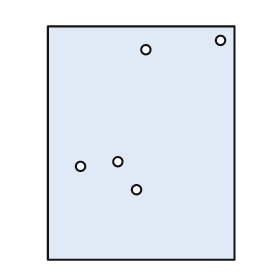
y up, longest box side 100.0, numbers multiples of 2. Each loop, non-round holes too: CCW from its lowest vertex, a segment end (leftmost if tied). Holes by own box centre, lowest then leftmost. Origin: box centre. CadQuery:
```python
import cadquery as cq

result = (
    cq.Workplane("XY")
    .moveTo(-40.0, -50.0)
    .lineTo(40.0, -50.0)
    .lineTo(40.0, 50.0)
    .lineTo(-40.0, 50.0)
    .close()
    .moveTo(-2.0, -20.0)
    .circle(2.0)
    .moveTo(-26.0, -10.0)
    .circle(2.0)
    .moveTo(-10.0, -8.0)
    .circle(2.0)
    .moveTo(2.0, 40.0)
    .circle(2.0)
    .moveTo(34.0, 44.0)
    .circle(2.0)
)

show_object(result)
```